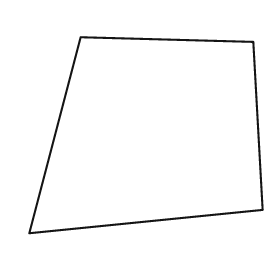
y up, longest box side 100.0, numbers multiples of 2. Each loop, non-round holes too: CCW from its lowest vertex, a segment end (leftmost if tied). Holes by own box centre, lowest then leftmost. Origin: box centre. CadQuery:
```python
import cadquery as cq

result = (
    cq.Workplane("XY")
    .moveTo(-50.0, -42.0)
    .lineTo(50.0, -32.0)
    .lineTo(46.0, 40.0)
    .lineTo(-28.0, 42.0)
    .close()
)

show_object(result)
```